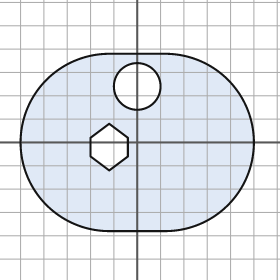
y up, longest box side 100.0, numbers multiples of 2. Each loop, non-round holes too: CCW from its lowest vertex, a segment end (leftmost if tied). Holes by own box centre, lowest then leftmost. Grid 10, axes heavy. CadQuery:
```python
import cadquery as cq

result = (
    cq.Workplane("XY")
    .moveTo(-12.0, -38.0)
    .lineTo(12.0, -38.0)
    .threePointArc((50.0, 0.0), (12.0, 38.0))
    .lineTo(-12.0, 38.0)
    .threePointArc((-50.0, 0.0), (-12.0, -38.0))
    .close()
    .moveTo(-12.0, -12.0)
    .lineTo(-4.0, -6.0)
    .lineTo(-4.0, 2.0)
    .lineTo(-12.0, 8.0)
    .lineTo(-20.0, 2.0)
    .lineTo(-20.0, -6.0)
    .close()
    .moveTo(0.0, 24.0)
    .circle(10.0)
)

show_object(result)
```